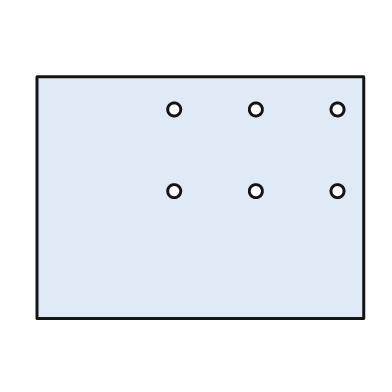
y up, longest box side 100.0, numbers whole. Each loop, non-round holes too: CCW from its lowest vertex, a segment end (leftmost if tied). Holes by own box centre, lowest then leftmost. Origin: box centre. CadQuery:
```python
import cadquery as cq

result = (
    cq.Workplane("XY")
    .moveTo(-50.0, -37.0)
    .lineTo(50.0, -37.0)
    .lineTo(50.0, 37.0)
    .lineTo(-50.0, 37.0)
    .close()
    .moveTo(-8.0, 2.0)
    .circle(2.0)
    .moveTo(17.0, 2.0)
    .circle(2.0)
    .moveTo(42.0, 2.0)
    .circle(2.0)
    .moveTo(-8.0, 27.0)
    .circle(2.0)
    .moveTo(17.0, 27.0)
    .circle(2.0)
    .moveTo(42.0, 27.0)
    .circle(2.0)
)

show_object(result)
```